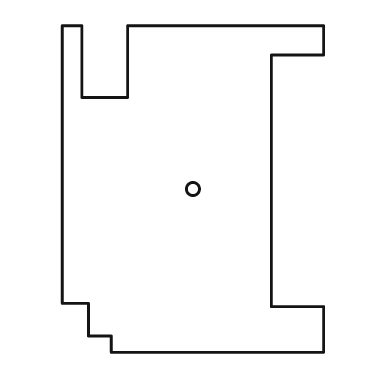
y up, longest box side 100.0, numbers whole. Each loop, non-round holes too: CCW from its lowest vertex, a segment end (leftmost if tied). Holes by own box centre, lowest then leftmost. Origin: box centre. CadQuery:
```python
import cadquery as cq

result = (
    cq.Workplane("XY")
    .moveTo(-25.0, -50.0)
    .lineTo(40.0, -50.0)
    .lineTo(40.0, -36.0)
    .lineTo(24.0, -36.0)
    .lineTo(24.0, 41.0)
    .lineTo(40.0, 41.0)
    .lineTo(40.0, 50.0)
    .lineTo(-20.0, 50.0)
    .lineTo(-20.0, 28.0)
    .lineTo(-34.0, 28.0)
    .lineTo(-34.0, 50.0)
    .lineTo(-40.0, 50.0)
    .lineTo(-40.0, -35.0)
    .lineTo(-32.0, -35.0)
    .lineTo(-32.0, -45.0)
    .lineTo(-25.0, -45.0)
    .close()
    .moveTo(0.0, 0.0)
    .circle(2.0)
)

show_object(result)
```